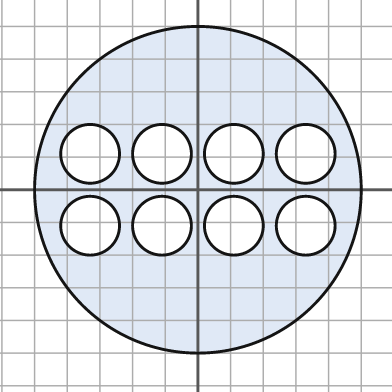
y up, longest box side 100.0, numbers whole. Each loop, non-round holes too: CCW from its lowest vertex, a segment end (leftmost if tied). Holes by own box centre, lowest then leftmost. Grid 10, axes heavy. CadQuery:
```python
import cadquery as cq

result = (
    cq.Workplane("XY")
    .moveTo(0.0, 0.0)
    .circle(50.0)
    .moveTo(-33.0, -11.0)
    .circle(9.0)
    .moveTo(-11.0, -11.0)
    .circle(9.0)
    .moveTo(11.0, -11.0)
    .circle(9.0)
    .moveTo(33.0, -11.0)
    .circle(9.0)
    .moveTo(-33.0, 11.0)
    .circle(9.0)
    .moveTo(-11.0, 11.0)
    .circle(9.0)
    .moveTo(11.0, 11.0)
    .circle(9.0)
    .moveTo(33.0, 11.0)
    .circle(9.0)
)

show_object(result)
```